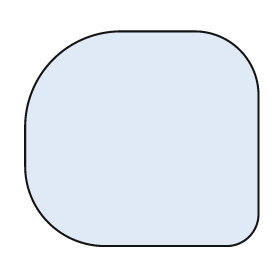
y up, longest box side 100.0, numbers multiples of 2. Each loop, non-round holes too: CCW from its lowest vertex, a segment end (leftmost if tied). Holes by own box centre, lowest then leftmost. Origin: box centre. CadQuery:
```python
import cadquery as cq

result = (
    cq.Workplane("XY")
    .moveTo(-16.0, -46.0)
    .lineTo(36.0, -46.0)
    .threePointArc((46.0, -42.0), (50.0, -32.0))
    .lineTo(50.0, 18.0)
    .threePointArc((42.0, 38.0), (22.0, 46.0))
    .lineTo(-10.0, 46.0)
    .threePointArc((-38.0, 34.0), (-50.0, 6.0))
    .lineTo(-50.0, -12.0)
    .threePointArc((-40.0, -36.0), (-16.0, -46.0))
    .close()
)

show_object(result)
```